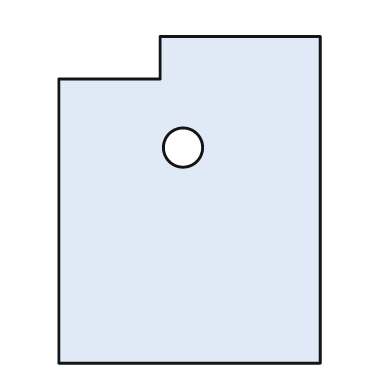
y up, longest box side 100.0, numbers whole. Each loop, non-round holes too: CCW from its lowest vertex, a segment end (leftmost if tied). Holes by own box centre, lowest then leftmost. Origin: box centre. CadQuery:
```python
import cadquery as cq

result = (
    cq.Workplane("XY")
    .moveTo(-40.0, -50.0)
    .lineTo(40.0, -50.0)
    .lineTo(40.0, 50.0)
    .lineTo(-9.0, 50.0)
    .lineTo(-9.0, 37.0)
    .lineTo(-40.0, 37.0)
    .close()
    .moveTo(-2.0, 16.0)
    .circle(6.0)
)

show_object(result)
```